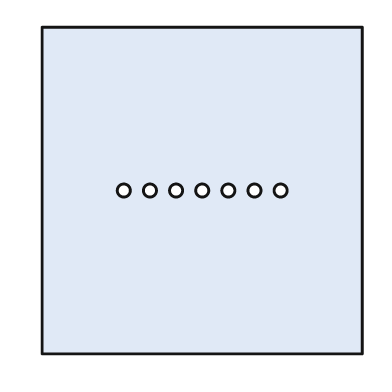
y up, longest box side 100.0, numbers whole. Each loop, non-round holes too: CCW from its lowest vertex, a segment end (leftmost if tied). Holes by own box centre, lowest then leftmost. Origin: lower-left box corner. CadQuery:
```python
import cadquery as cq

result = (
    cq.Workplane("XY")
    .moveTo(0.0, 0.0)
    .lineTo(98.0, 0.0)
    .lineTo(98.0, 100.0)
    .lineTo(0.0, 100.0)
    .close()
    .moveTo(25.0, 50.0)
    .circle(2.0)
    .moveTo(33.0, 50.0)
    .circle(2.0)
    .moveTo(41.0, 50.0)
    .circle(2.0)
    .moveTo(49.0, 50.0)
    .circle(2.0)
    .moveTo(57.0, 50.0)
    .circle(2.0)
    .moveTo(65.0, 50.0)
    .circle(2.0)
    .moveTo(73.0, 50.0)
    .circle(2.0)
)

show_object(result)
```